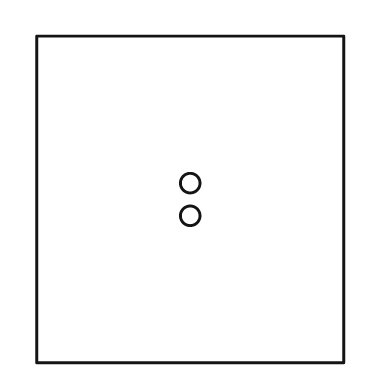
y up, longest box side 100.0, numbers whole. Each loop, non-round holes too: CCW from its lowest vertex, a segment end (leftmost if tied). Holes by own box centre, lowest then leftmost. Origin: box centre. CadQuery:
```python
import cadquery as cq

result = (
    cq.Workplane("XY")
    .moveTo(-47.0, -50.0)
    .lineTo(47.0, -50.0)
    .lineTo(47.0, 50.0)
    .lineTo(-47.0, 50.0)
    .close()
    .moveTo(0.0, -5.0)
    .circle(3.0)
    .moveTo(0.0, 5.0)
    .circle(3.0)
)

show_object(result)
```